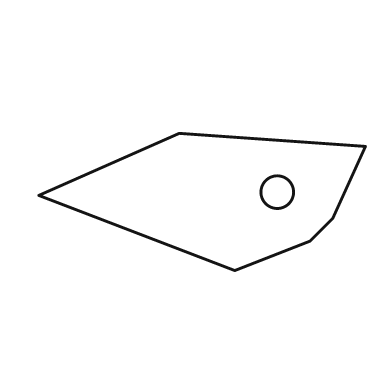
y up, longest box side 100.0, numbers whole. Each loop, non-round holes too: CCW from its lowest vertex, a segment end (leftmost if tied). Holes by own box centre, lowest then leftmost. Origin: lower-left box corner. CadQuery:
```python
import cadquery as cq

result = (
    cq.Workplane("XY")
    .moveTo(60.0, 0.0)
    .lineTo(83.0, 9.0)
    .lineTo(90.0, 16.0)
    .lineTo(100.0, 38.0)
    .lineTo(43.0, 42.0)
    .lineTo(0.0, 23.0)
    .close()
    .moveTo(73.0, 24.0)
    .circle(5.0)
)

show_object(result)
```